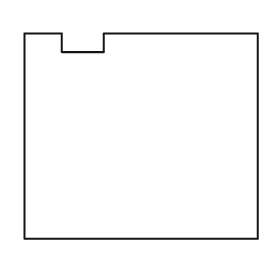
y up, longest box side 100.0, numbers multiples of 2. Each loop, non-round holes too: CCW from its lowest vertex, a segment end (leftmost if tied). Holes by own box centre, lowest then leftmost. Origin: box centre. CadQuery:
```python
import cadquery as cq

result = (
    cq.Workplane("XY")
    .moveTo(-50.0, -44.0)
    .lineTo(50.0, -44.0)
    .lineTo(50.0, 44.0)
    .lineTo(-16.0, 44.0)
    .lineTo(-16.0, 36.0)
    .lineTo(-34.0, 36.0)
    .lineTo(-34.0, 44.0)
    .lineTo(-50.0, 44.0)
    .close()
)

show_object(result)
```